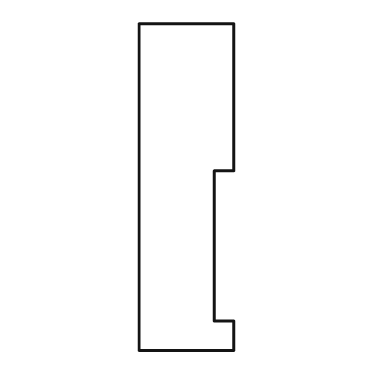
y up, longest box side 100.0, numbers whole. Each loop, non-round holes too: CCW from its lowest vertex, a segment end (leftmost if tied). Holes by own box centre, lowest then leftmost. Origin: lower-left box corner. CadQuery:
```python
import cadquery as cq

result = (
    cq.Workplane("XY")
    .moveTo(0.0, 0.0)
    .lineTo(29.0, 0.0)
    .lineTo(29.0, 9.0)
    .lineTo(23.0, 9.0)
    .lineTo(23.0, 55.0)
    .lineTo(29.0, 55.0)
    .lineTo(29.0, 100.0)
    .lineTo(0.0, 100.0)
    .close()
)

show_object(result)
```